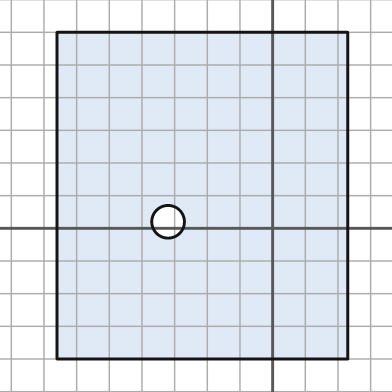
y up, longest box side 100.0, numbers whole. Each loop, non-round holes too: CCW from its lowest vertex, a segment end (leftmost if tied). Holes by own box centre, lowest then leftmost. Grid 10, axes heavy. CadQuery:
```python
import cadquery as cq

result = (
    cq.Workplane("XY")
    .moveTo(-66.0, -40.0)
    .lineTo(23.0, -40.0)
    .lineTo(23.0, 60.0)
    .lineTo(-66.0, 60.0)
    .close()
    .moveTo(-32.0, 2.0)
    .circle(5.0)
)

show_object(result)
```